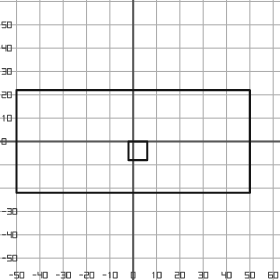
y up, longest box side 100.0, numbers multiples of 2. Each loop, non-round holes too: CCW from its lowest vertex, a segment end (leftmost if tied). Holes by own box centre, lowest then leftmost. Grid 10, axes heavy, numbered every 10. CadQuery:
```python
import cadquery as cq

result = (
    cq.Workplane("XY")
    .moveTo(-50.0, -22.0)
    .lineTo(50.0, -22.0)
    .lineTo(50.0, 22.0)
    .lineTo(-50.0, 22.0)
    .close()
    .moveTo(-2.0, -8.0)
    .lineTo(6.0, -8.0)
    .lineTo(6.0, 0.0)
    .lineTo(-2.0, 0.0)
    .close()
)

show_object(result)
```